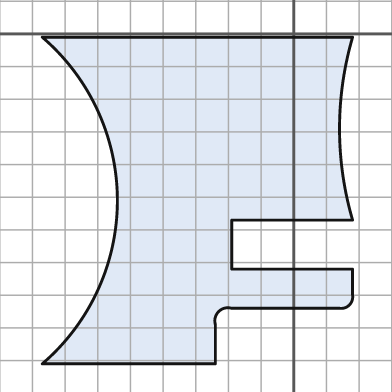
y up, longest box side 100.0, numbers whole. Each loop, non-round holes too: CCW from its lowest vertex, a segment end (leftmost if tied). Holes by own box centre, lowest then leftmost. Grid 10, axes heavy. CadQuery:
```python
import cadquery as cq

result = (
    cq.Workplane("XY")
    .moveTo(-77.0, -101.0)
    .lineTo(-24.0, -101.0)
    .lineTo(-24.0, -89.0)
    .threePointArc((-23.0, -85.0), (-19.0, -84.0))
    .lineTo(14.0, -84.0)
    .threePointArc((17.0, -83.0), (18.0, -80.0))
    .lineTo(18.0, -72.0)
    .lineTo(-19.0, -72.0)
    .lineTo(-19.0, -57.0)
    .lineTo(18.0, -57.0)
    .threePointArc((14.0, -29.0), (18.0, -1.0))
    .lineTo(-77.0, -1.0)
    .threePointArc((-54.0, -51.0), (-77.0, -101.0))
    .close()
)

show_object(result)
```